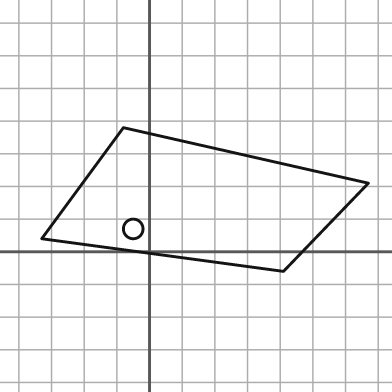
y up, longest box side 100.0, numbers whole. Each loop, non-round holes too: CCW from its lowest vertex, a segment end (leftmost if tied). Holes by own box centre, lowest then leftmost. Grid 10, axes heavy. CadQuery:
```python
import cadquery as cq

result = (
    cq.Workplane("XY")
    .moveTo(41.0, -6.0)
    .lineTo(67.0, 21.0)
    .lineTo(-8.0, 38.0)
    .lineTo(-33.0, 4.0)
    .close()
    .moveTo(-5.0, 7.0)
    .circle(3.0)
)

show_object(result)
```